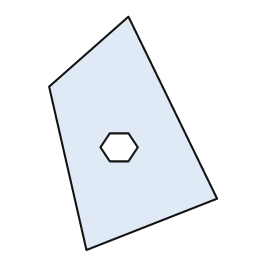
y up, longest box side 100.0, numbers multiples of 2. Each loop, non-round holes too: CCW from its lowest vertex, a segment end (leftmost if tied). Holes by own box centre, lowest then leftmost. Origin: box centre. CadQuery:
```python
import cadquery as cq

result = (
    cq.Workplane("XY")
    .moveTo(-20.0, -50.0)
    .lineTo(36.0, -28.0)
    .lineTo(-2.0, 50.0)
    .lineTo(-36.0, 20.0)
    .close()
    .moveTo(-10.0, -12.0)
    .lineTo(-2.0, -12.0)
    .lineTo(2.0, -6.0)
    .lineTo(-2.0, 0.0)
    .lineTo(-10.0, 0.0)
    .lineTo(-14.0, -6.0)
    .close()
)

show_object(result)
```